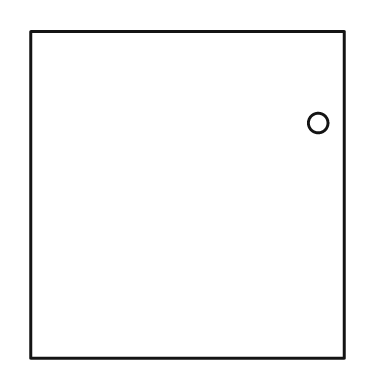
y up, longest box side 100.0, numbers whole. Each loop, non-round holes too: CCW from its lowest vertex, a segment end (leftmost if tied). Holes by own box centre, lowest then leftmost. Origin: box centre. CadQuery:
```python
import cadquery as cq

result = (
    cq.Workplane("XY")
    .moveTo(-48.0, -50.0)
    .lineTo(48.0, -50.0)
    .lineTo(48.0, 50.0)
    .lineTo(-48.0, 50.0)
    .close()
    .moveTo(40.0, 22.0)
    .circle(3.0)
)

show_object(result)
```